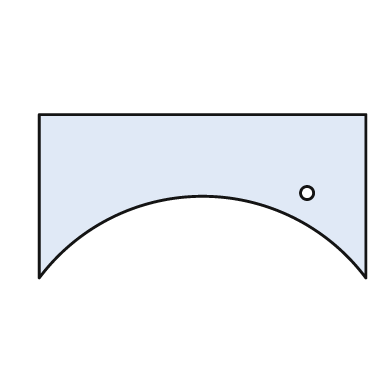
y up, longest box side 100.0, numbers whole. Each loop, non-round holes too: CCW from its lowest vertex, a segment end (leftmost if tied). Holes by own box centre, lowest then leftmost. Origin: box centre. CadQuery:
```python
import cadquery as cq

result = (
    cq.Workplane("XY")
    .moveTo(-50.0, -25.0)
    .threePointArc((0.0, 0.0), (50.0, -25.0))
    .lineTo(50.0, 25.0)
    .lineTo(-50.0, 25.0)
    .close()
    .moveTo(32.0, 1.0)
    .circle(2.0)
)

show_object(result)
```